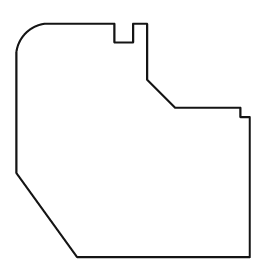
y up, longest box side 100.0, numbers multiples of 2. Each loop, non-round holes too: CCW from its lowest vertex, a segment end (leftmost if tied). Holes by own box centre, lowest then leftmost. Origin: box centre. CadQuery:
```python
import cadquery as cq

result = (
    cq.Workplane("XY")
    .moveTo(-24.0, -50.0)
    .lineTo(50.0, -50.0)
    .lineTo(50.0, 10.0)
    .lineTo(46.0, 10.0)
    .lineTo(46.0, 14.0)
    .lineTo(18.0, 14.0)
    .lineTo(6.0, 26.0)
    .lineTo(6.0, 50.0)
    .lineTo(0.0, 50.0)
    .lineTo(0.0, 42.0)
    .lineTo(-8.0, 42.0)
    .lineTo(-8.0, 50.0)
    .lineTo(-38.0, 50.0)
    .threePointArc((-46.0, 46.0), (-50.0, 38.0))
    .lineTo(-50.0, -14.0)
    .close()
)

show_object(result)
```